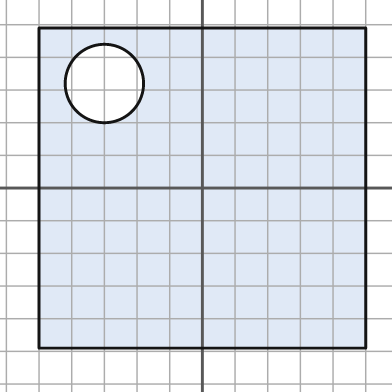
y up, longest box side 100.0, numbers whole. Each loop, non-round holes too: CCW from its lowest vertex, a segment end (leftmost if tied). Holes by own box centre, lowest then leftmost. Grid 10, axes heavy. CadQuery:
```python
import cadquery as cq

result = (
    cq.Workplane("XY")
    .moveTo(-50.0, -49.0)
    .lineTo(50.0, -49.0)
    .lineTo(50.0, 49.0)
    .lineTo(-50.0, 49.0)
    .close()
    .moveTo(-30.0, 32.0)
    .circle(12.0)
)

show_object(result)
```